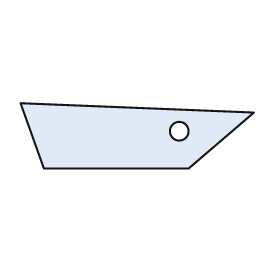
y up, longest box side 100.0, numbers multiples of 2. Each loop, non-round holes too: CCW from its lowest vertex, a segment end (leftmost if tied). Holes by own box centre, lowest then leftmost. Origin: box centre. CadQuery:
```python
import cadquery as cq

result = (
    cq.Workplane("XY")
    .moveTo(-40.0, -14.0)
    .lineTo(22.0, -14.0)
    .lineTo(50.0, 10.0)
    .lineTo(-50.0, 14.0)
    .close()
    .moveTo(18.0, 2.0)
    .circle(4.0)
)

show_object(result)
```